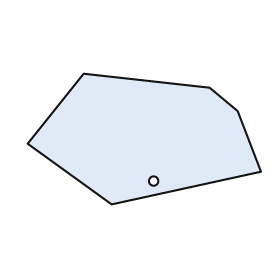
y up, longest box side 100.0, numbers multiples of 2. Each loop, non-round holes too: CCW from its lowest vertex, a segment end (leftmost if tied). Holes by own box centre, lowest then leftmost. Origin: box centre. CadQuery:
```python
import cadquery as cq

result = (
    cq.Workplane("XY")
    .moveTo(-14.0, -28.0)
    .lineTo(50.0, -14.0)
    .lineTo(40.0, 12.0)
    .lineTo(28.0, 22.0)
    .lineTo(-26.0, 28.0)
    .lineTo(-50.0, -2.0)
    .close()
    .moveTo(4.0, -18.0)
    .circle(2.0)
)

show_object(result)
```